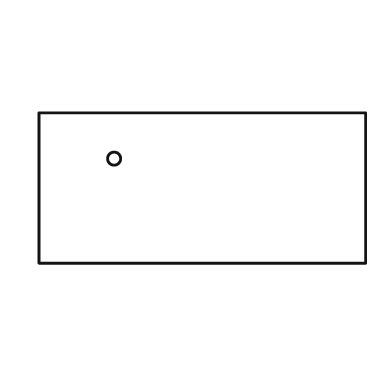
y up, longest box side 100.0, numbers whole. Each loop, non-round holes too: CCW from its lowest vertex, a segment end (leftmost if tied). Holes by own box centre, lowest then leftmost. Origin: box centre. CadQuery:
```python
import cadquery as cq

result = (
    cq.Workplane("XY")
    .moveTo(-50.0, -23.0)
    .lineTo(50.0, -23.0)
    .lineTo(50.0, 23.0)
    .lineTo(-50.0, 23.0)
    .close()
    .moveTo(-27.0, 9.0)
    .circle(2.0)
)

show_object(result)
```